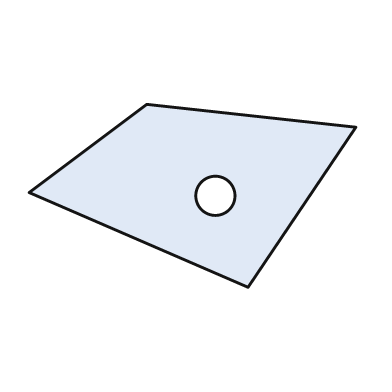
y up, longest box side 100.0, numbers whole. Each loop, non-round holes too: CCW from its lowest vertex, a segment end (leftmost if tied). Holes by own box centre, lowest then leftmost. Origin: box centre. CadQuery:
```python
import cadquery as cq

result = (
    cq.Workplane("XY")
    .moveTo(17.0, -28.0)
    .lineTo(50.0, 21.0)
    .lineTo(-14.0, 28.0)
    .lineTo(-50.0, 1.0)
    .close()
    .moveTo(7.0, 0.0)
    .circle(6.0)
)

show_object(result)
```